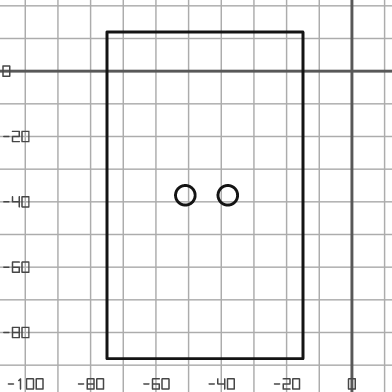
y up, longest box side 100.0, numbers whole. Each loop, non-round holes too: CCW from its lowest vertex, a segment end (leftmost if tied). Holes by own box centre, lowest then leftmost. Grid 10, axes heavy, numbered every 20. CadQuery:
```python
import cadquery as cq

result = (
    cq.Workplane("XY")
    .moveTo(-75.0, -88.0)
    .lineTo(-15.0, -88.0)
    .lineTo(-15.0, 12.0)
    .lineTo(-75.0, 12.0)
    .close()
    .moveTo(-51.0, -38.0)
    .circle(3.0)
    .moveTo(-38.0, -38.0)
    .circle(3.0)
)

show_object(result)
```